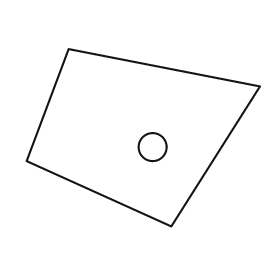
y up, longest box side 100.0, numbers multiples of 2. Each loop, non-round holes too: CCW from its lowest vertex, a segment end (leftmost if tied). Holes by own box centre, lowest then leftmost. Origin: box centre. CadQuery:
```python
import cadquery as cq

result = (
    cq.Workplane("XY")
    .moveTo(12.0, -38.0)
    .lineTo(50.0, 22.0)
    .lineTo(-32.0, 38.0)
    .lineTo(-50.0, -10.0)
    .close()
    .moveTo(4.0, -4.0)
    .circle(6.0)
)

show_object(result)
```